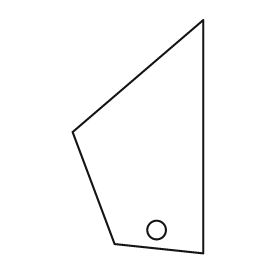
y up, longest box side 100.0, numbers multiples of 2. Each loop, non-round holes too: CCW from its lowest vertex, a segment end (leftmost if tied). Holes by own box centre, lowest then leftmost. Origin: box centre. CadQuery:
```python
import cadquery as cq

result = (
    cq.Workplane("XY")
    .moveTo(28.0, -50.0)
    .lineTo(28.0, 50.0)
    .lineTo(-28.0, 2.0)
    .lineTo(-10.0, -46.0)
    .close()
    .moveTo(8.0, -40.0)
    .circle(4.0)
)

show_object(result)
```